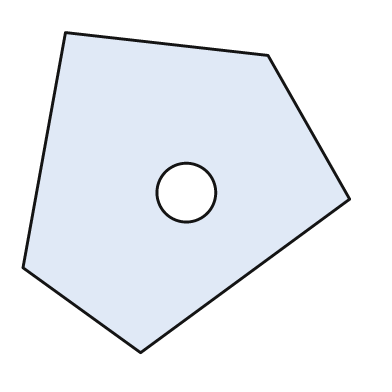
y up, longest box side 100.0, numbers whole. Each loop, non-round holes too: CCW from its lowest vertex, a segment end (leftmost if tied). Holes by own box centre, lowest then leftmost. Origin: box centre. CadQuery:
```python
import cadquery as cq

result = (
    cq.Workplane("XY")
    .moveTo(-14.0, -49.0)
    .lineTo(50.0, -2.0)
    .lineTo(25.0, 42.0)
    .lineTo(-37.0, 49.0)
    .lineTo(-50.0, -23.0)
    .close()
    .moveTo(0.0, 0.0)
    .circle(9.0)
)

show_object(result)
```